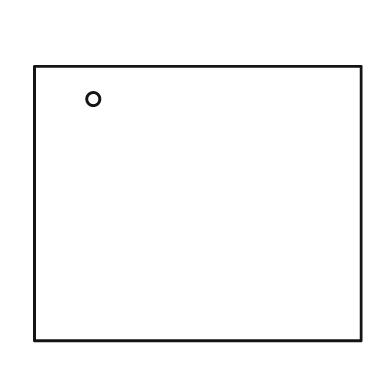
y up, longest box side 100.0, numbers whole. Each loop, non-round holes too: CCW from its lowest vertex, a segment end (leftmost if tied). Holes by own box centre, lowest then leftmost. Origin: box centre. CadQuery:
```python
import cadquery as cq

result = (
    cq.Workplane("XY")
    .moveTo(-50.0, -42.0)
    .lineTo(50.0, -42.0)
    .lineTo(50.0, 42.0)
    .lineTo(-50.0, 42.0)
    .close()
    .moveTo(-32.0, 32.0)
    .circle(2.0)
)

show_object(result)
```